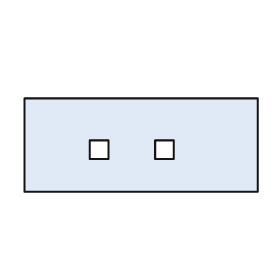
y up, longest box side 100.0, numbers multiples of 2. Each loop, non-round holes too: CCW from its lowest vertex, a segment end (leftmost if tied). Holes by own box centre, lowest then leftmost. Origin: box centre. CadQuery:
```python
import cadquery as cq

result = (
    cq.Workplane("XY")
    .moveTo(-50.0, -20.0)
    .lineTo(50.0, -20.0)
    .lineTo(50.0, 20.0)
    .lineTo(-50.0, 20.0)
    .close()
    .moveTo(-22.0, -6.0)
    .lineTo(-14.0, -6.0)
    .lineTo(-14.0, 2.0)
    .lineTo(-22.0, 2.0)
    .close()
    .moveTo(6.0, -6.0)
    .lineTo(14.0, -6.0)
    .lineTo(14.0, 2.0)
    .lineTo(6.0, 2.0)
    .close()
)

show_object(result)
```